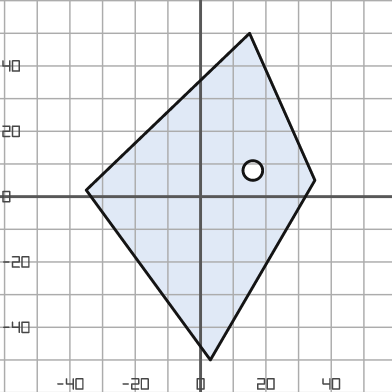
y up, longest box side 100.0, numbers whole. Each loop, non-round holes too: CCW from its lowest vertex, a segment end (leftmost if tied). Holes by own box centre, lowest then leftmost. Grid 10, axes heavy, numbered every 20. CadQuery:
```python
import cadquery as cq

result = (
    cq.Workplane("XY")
    .moveTo(3.0, -50.0)
    .lineTo(35.0, 5.0)
    .lineTo(15.0, 50.0)
    .lineTo(-35.0, 2.0)
    .close()
    .moveTo(16.0, 8.0)
    .circle(3.0)
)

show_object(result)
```